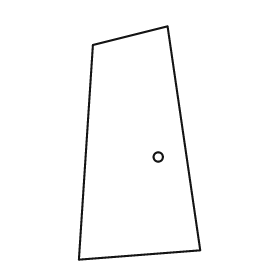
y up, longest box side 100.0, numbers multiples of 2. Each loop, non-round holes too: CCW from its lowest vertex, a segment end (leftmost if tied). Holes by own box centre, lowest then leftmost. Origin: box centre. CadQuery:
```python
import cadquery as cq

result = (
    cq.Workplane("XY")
    .moveTo(-26.0, -50.0)
    .lineTo(26.0, -46.0)
    .lineTo(12.0, 50.0)
    .lineTo(-20.0, 42.0)
    .close()
    .moveTo(8.0, -6.0)
    .circle(2.0)
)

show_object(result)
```